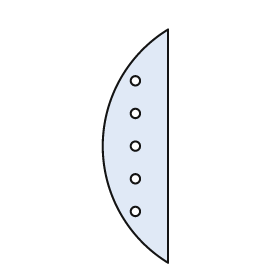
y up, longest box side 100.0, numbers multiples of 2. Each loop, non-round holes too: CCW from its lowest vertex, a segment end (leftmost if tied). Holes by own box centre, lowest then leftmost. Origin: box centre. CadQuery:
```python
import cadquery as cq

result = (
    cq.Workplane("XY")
    .moveTo(14.0, -50.0)
    .lineTo(14.0, 50.0)
    .threePointArc((-14.0, 0.0), (14.0, -50.0))
    .close()
    .moveTo(0.0, -28.0)
    .circle(2.0)
    .moveTo(0.0, -14.0)
    .circle(2.0)
    .moveTo(0.0, 0.0)
    .circle(2.0)
    .moveTo(0.0, 14.0)
    .circle(2.0)
    .moveTo(0.0, 28.0)
    .circle(2.0)
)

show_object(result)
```